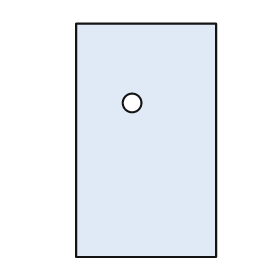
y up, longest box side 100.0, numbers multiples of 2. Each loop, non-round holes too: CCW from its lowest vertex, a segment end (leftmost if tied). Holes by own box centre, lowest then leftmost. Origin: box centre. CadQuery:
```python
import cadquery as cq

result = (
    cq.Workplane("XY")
    .moveTo(-30.0, -50.0)
    .lineTo(30.0, -50.0)
    .lineTo(30.0, 50.0)
    .lineTo(-30.0, 50.0)
    .close()
    .moveTo(-6.0, 16.0)
    .circle(4.0)
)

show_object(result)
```